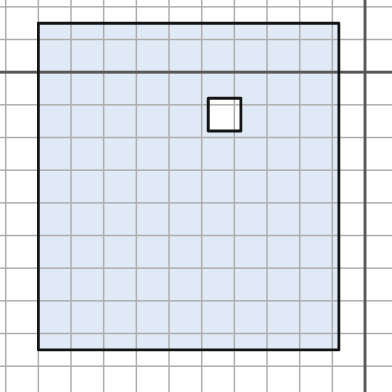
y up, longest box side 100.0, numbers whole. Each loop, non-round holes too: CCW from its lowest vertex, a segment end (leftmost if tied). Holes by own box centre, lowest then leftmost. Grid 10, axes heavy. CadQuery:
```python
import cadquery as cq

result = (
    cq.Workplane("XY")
    .moveTo(-100.0, -85.0)
    .lineTo(-8.0, -85.0)
    .lineTo(-8.0, 15.0)
    .lineTo(-100.0, 15.0)
    .close()
    .moveTo(-48.0, -18.0)
    .lineTo(-38.0, -18.0)
    .lineTo(-38.0, -8.0)
    .lineTo(-48.0, -8.0)
    .close()
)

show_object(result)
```